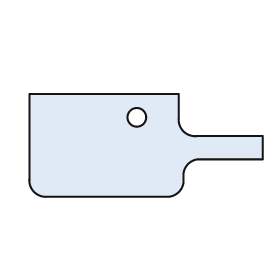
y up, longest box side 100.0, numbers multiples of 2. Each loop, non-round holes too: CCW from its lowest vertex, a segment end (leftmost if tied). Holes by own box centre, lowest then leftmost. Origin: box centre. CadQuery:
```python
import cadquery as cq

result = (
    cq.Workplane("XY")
    .moveTo(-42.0, -22.0)
    .lineTo(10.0, -22.0)
    .threePointArc((14.0, -20.0), (16.0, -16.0))
    .lineTo(16.0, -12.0)
    .threePointArc((18.0, -8.0), (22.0, -6.0))
    .lineTo(50.0, -6.0)
    .lineTo(50.0, 4.0)
    .lineTo(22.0, 4.0)
    .threePointArc((16.0, 6.0), (14.0, 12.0))
    .lineTo(14.0, 22.0)
    .lineTo(-50.0, 22.0)
    .lineTo(-50.0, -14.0)
    .threePointArc((-48.0, -20.0), (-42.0, -22.0))
    .close()
    .moveTo(-4.0, 12.0)
    .circle(4.0)
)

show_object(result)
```